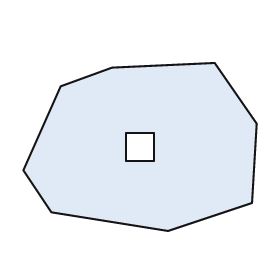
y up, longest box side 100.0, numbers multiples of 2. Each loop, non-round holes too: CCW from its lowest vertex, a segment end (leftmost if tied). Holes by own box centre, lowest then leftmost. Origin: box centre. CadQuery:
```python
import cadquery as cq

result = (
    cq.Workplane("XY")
    .moveTo(12.0, -36.0)
    .lineTo(48.0, -24.0)
    .lineTo(50.0, 10.0)
    .lineTo(32.0, 36.0)
    .lineTo(-12.0, 34.0)
    .lineTo(-34.0, 26.0)
    .lineTo(-50.0, -10.0)
    .lineTo(-38.0, -28.0)
    .close()
    .moveTo(-6.0, -6.0)
    .lineTo(6.0, -6.0)
    .lineTo(6.0, 6.0)
    .lineTo(-6.0, 6.0)
    .close()
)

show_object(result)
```